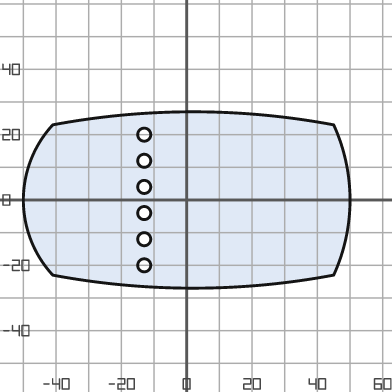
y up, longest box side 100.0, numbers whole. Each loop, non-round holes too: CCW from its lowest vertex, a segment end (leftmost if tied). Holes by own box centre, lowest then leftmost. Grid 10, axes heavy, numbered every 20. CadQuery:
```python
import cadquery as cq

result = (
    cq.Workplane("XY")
    .moveTo(-41.0, -23.0)
    .threePointArc((2.0, -27.0), (45.0, -23.0))
    .threePointArc((50.0, 0.0), (45.0, 23.0))
    .threePointArc((2.0, 27.0), (-41.0, 23.0))
    .threePointArc((-50.0, 0.0), (-41.0, -23.0))
    .close()
    .moveTo(-13.0, -20.0)
    .circle(2.0)
    .moveTo(-13.0, -12.0)
    .circle(2.0)
    .moveTo(-13.0, -4.0)
    .circle(2.0)
    .moveTo(-13.0, 4.0)
    .circle(2.0)
    .moveTo(-13.0, 12.0)
    .circle(2.0)
    .moveTo(-13.0, 20.0)
    .circle(2.0)
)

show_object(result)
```